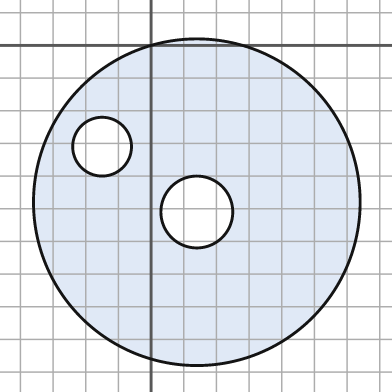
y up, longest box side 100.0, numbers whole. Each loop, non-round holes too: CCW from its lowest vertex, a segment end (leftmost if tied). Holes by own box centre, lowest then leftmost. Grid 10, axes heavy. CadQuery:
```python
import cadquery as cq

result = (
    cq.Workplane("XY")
    .moveTo(14.0, -48.0)
    .circle(50.0)
    .moveTo(14.0, -51.0)
    .circle(11.0)
    .moveTo(-15.0, -31.0)
    .circle(9.0)
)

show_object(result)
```